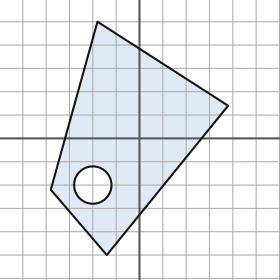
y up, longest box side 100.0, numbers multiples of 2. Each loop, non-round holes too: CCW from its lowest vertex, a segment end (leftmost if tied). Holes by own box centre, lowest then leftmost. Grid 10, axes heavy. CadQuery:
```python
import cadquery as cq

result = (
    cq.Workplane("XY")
    .moveTo(-14.0, -50.0)
    .lineTo(38.0, 14.0)
    .lineTo(-18.0, 50.0)
    .lineTo(-38.0, -22.0)
    .close()
    .moveTo(-20.0, -20.0)
    .circle(8.0)
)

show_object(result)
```